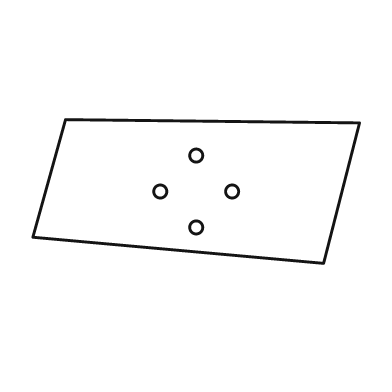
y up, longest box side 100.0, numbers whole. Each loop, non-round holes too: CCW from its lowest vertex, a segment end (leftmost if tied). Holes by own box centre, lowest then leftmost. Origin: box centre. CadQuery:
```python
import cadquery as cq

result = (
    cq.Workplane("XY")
    .moveTo(39.0, -22.0)
    .lineTo(50.0, 21.0)
    .lineTo(-40.0, 22.0)
    .lineTo(-50.0, -14.0)
    .close()
    .moveTo(0.0, -11.0)
    .circle(2.0)
    .moveTo(-11.0, 0.0)
    .circle(2.0)
    .moveTo(11.0, 0.0)
    .circle(2.0)
    .moveTo(0.0, 11.0)
    .circle(2.0)
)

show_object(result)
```